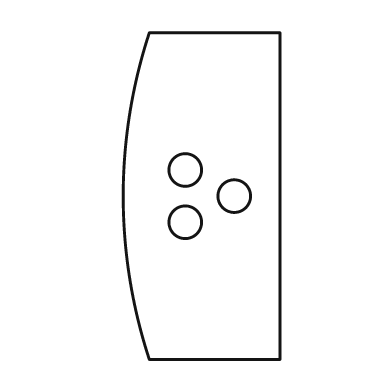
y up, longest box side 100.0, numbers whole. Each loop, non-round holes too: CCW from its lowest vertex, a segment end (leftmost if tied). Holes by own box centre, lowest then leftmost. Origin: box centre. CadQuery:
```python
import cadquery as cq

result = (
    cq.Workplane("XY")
    .moveTo(-16.0, -50.0)
    .lineTo(24.0, -50.0)
    .lineTo(24.0, 50.0)
    .lineTo(-16.0, 50.0)
    .threePointArc((-24.0, 0.0), (-16.0, -50.0))
    .close()
    .moveTo(-5.0, -8.0)
    .circle(5.0)
    .moveTo(10.0, 0.0)
    .circle(5.0)
    .moveTo(-5.0, 8.0)
    .circle(5.0)
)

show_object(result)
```